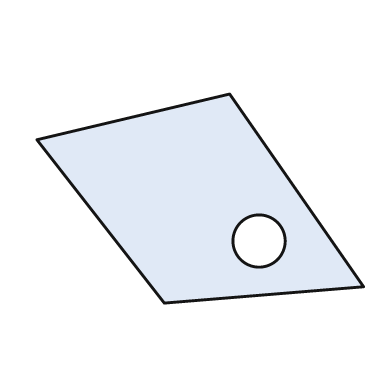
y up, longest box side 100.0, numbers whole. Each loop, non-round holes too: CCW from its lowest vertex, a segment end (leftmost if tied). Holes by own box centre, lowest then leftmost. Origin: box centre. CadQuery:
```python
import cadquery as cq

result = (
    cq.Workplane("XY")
    .moveTo(-11.0, -32.0)
    .lineTo(50.0, -27.0)
    .lineTo(9.0, 32.0)
    .lineTo(-50.0, 18.0)
    .close()
    .moveTo(18.0, -13.0)
    .circle(8.0)
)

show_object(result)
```